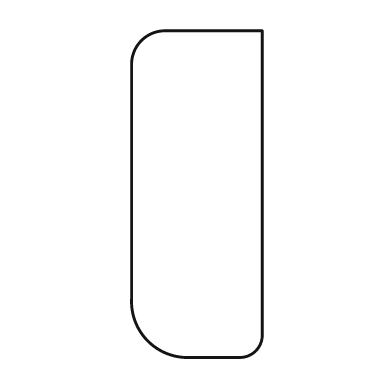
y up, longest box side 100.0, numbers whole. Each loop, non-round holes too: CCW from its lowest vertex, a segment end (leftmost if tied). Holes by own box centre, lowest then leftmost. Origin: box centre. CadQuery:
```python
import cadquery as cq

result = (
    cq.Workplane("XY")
    .moveTo(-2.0, -50.0)
    .lineTo(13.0, -50.0)
    .threePointArc((18.0, -48.0), (20.0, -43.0))
    .lineTo(20.0, 50.0)
    .lineTo(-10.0, 50.0)
    .threePointArc((-17.0, 47.0), (-20.0, 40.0))
    .lineTo(-20.0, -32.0)
    .threePointArc((-15.0, -45.0), (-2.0, -50.0))
    .close()
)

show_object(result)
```